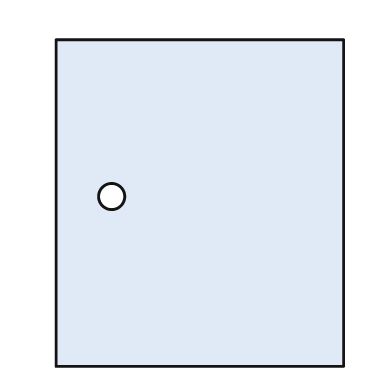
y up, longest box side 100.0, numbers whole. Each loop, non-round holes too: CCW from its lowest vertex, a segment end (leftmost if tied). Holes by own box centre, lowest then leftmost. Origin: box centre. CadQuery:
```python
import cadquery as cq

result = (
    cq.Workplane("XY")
    .moveTo(-44.0, -50.0)
    .lineTo(44.0, -50.0)
    .lineTo(44.0, 50.0)
    .lineTo(-44.0, 50.0)
    .close()
    .moveTo(-27.0, 2.0)
    .circle(4.0)
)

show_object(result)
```